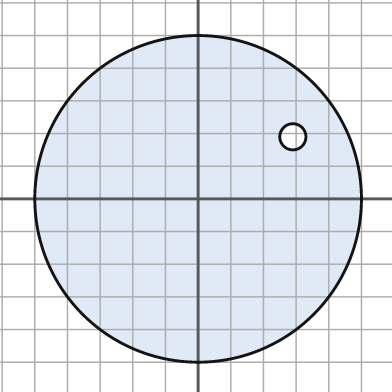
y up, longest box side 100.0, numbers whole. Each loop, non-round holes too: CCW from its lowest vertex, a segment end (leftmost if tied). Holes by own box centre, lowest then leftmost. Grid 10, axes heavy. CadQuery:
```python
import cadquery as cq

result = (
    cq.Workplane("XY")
    .moveTo(0.0, 0.0)
    .circle(50.0)
    .moveTo(29.0, 19.0)
    .circle(4.0)
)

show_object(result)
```